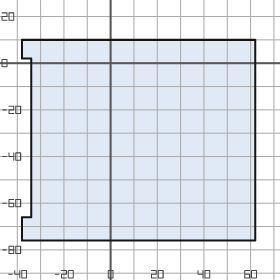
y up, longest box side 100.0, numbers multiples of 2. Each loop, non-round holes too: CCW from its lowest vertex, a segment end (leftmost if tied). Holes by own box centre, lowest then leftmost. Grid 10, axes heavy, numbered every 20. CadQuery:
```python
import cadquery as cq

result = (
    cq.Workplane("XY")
    .moveTo(-38.0, -76.0)
    .lineTo(62.0, -76.0)
    .lineTo(62.0, 10.0)
    .lineTo(-38.0, 10.0)
    .lineTo(-38.0, 2.0)
    .lineTo(-34.0, 2.0)
    .lineTo(-34.0, -66.0)
    .lineTo(-38.0, -66.0)
    .close()
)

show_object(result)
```